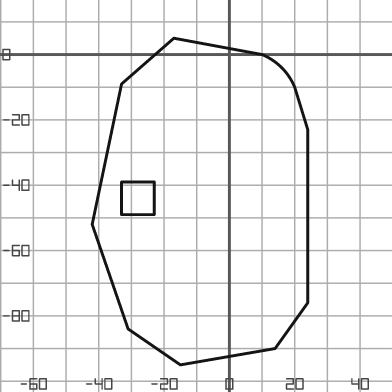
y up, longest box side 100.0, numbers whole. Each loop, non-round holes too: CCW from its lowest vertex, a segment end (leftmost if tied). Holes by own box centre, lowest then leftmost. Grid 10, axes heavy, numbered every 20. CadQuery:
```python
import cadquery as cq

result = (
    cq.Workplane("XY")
    .moveTo(-15.0, -95.0)
    .lineTo(14.0, -90.0)
    .lineTo(24.0, -76.0)
    .lineTo(24.0, -23.0)
    .lineTo(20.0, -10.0)
    .threePointArc((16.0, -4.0), (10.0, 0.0))
    .lineTo(-17.0, 5.0)
    .lineTo(-33.0, -9.0)
    .lineTo(-42.0, -52.0)
    .lineTo(-31.0, -84.0)
    .close()
    .moveTo(-33.0, -49.0)
    .lineTo(-23.0, -49.0)
    .lineTo(-23.0, -39.0)
    .lineTo(-33.0, -39.0)
    .close()
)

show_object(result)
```